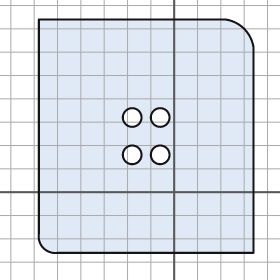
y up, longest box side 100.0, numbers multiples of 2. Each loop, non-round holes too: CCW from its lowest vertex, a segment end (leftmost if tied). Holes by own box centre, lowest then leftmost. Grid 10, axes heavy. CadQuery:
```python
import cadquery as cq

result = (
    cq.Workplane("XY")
    .moveTo(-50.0, -26.0)
    .lineTo(34.0, -26.0)
    .lineTo(34.0, 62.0)
    .threePointArc((30.0, 70.0), (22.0, 74.0))
    .lineTo(-58.0, 74.0)
    .lineTo(-58.0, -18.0)
    .threePointArc((-56.0, -24.0), (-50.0, -26.0))
    .close()
    .moveTo(-18.0, 16.0)
    .circle(4.0)
    .moveTo(-6.0, 16.0)
    .circle(4.0)
    .moveTo(-18.0, 32.0)
    .circle(4.0)
    .moveTo(-6.0, 32.0)
    .circle(4.0)
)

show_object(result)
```